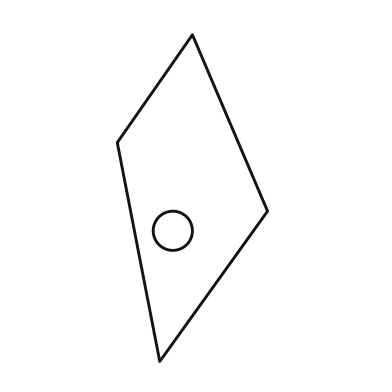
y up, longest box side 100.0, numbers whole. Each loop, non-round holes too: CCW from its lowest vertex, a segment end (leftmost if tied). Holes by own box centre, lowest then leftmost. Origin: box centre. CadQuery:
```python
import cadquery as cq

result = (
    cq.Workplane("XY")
    .moveTo(-10.0, -50.0)
    .lineTo(23.0, -4.0)
    .lineTo(0.0, 50.0)
    .lineTo(-23.0, 17.0)
    .close()
    .moveTo(-6.0, -10.0)
    .circle(6.0)
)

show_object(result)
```